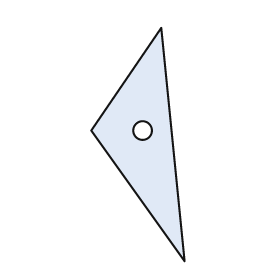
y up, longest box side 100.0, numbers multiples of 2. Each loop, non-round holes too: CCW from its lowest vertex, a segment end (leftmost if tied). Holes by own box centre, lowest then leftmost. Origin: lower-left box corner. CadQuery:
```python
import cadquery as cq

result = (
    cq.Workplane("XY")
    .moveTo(40.0, 0.0)
    .lineTo(30.0, 100.0)
    .lineTo(0.0, 56.0)
    .close()
    .moveTo(22.0, 56.0)
    .circle(4.0)
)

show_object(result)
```